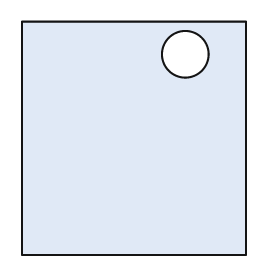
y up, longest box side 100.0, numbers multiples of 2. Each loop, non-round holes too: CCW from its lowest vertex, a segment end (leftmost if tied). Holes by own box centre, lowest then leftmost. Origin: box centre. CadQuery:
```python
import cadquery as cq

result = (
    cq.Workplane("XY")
    .moveTo(-48.0, -50.0)
    .lineTo(48.0, -50.0)
    .lineTo(48.0, 50.0)
    .lineTo(-48.0, 50.0)
    .close()
    .moveTo(22.0, 36.0)
    .circle(10.0)
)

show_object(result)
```